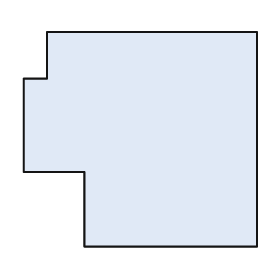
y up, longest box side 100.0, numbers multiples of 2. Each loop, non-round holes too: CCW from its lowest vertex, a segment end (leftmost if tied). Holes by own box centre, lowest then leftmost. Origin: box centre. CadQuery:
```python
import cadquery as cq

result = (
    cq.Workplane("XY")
    .moveTo(-24.0, -46.0)
    .lineTo(50.0, -46.0)
    .lineTo(50.0, 46.0)
    .lineTo(-40.0, 46.0)
    .lineTo(-40.0, 26.0)
    .lineTo(-50.0, 26.0)
    .lineTo(-50.0, -14.0)
    .lineTo(-24.0, -14.0)
    .close()
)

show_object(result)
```